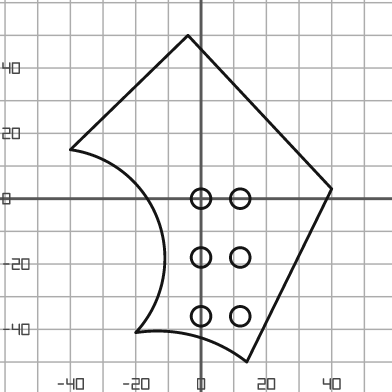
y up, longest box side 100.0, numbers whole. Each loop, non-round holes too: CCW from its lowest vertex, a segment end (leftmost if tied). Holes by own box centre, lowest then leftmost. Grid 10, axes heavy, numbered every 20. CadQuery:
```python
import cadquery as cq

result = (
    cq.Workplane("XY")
    .moveTo(14.0, -50.0)
    .lineTo(40.0, 3.0)
    .lineTo(-4.0, 50.0)
    .lineTo(-40.0, 15.0)
    .threePointArc((-13.0, -7.0), (-20.0, -41.0))
    .threePointArc((-2.0, -42.0), (14.0, -50.0))
    .close()
    .moveTo(0.0, -36.0)
    .circle(3.0)
    .moveTo(12.0, -36.0)
    .circle(3.0)
    .moveTo(0.0, -18.0)
    .circle(3.0)
    .moveTo(12.0, -18.0)
    .circle(3.0)
    .moveTo(0.0, 0.0)
    .circle(3.0)
    .moveTo(12.0, 0.0)
    .circle(3.0)
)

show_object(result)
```